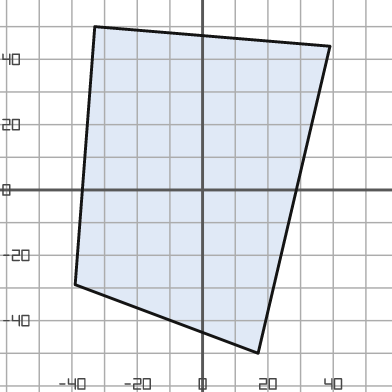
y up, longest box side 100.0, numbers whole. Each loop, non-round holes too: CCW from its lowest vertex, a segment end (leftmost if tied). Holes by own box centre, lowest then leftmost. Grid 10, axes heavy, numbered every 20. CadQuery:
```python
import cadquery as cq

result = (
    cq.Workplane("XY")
    .moveTo(17.0, -50.0)
    .lineTo(39.0, 44.0)
    .lineTo(-33.0, 50.0)
    .lineTo(-39.0, -29.0)
    .close()
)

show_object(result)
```